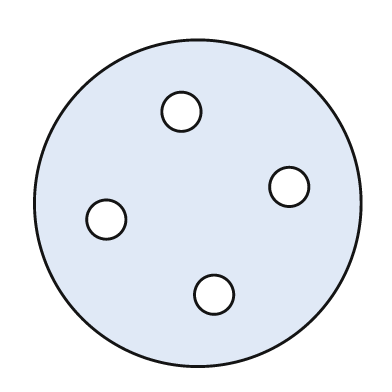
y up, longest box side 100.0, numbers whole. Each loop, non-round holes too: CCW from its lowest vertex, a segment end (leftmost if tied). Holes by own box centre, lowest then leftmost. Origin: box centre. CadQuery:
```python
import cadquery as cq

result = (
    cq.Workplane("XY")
    .moveTo(0.0, 0.0)
    .circle(50.0)
    .moveTo(5.0, -28.0)
    .circle(6.0)
    .moveTo(-28.0, -5.0)
    .circle(6.0)
    .moveTo(28.0, 5.0)
    .circle(6.0)
    .moveTo(-5.0, 28.0)
    .circle(6.0)
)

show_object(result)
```